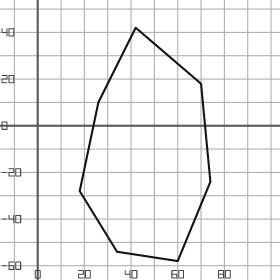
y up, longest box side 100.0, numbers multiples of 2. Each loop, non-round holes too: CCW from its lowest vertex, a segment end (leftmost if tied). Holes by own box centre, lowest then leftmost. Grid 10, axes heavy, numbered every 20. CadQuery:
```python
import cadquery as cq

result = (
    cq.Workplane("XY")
    .moveTo(60.0, -58.0)
    .lineTo(74.0, -24.0)
    .lineTo(70.0, 18.0)
    .lineTo(42.0, 42.0)
    .lineTo(26.0, 10.0)
    .lineTo(18.0, -28.0)
    .lineTo(34.0, -54.0)
    .close()
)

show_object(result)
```